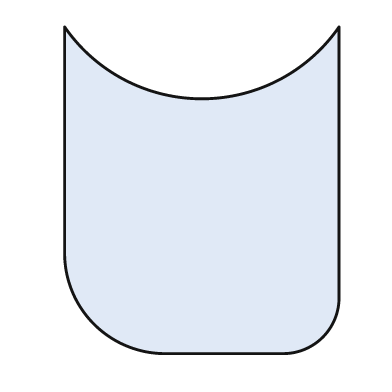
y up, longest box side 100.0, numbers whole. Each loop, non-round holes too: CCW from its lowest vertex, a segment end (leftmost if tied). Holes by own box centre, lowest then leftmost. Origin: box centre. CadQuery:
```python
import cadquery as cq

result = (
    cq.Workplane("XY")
    .moveTo(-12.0, -50.0)
    .lineTo(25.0, -50.0)
    .threePointArc((37.0, -45.0), (42.0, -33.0))
    .lineTo(42.0, 50.0)
    .threePointArc((0.0, 28.0), (-42.0, 50.0))
    .lineTo(-42.0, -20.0)
    .threePointArc((-33.0, -41.0), (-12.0, -50.0))
    .close()
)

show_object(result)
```